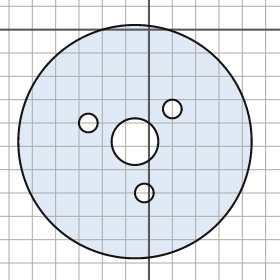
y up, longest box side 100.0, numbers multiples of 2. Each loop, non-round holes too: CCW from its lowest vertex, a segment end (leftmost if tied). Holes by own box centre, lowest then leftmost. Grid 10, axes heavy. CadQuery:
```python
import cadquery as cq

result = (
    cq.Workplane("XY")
    .moveTo(-6.0, -48.0)
    .circle(50.0)
    .moveTo(-2.0, -70.0)
    .circle(4.0)
    .moveTo(-6.0, -48.0)
    .circle(10.0)
    .moveTo(-26.0, -40.0)
    .circle(4.0)
    .moveTo(10.0, -34.0)
    .circle(4.0)
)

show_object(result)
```